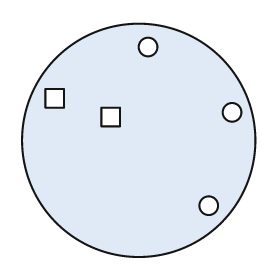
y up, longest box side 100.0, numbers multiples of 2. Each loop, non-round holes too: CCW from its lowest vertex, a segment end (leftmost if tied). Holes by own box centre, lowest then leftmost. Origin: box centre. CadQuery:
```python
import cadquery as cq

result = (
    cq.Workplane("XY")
    .moveTo(0.0, 0.0)
    .circle(50.0)
    .moveTo(30.0, -28.0)
    .circle(4.0)
    .moveTo(-16.0, 6.0)
    .lineTo(-8.0, 6.0)
    .lineTo(-8.0, 14.0)
    .lineTo(-16.0, 14.0)
    .close()
    .moveTo(40.0, 12.0)
    .circle(4.0)
    .moveTo(-40.0, 14.0)
    .lineTo(-32.0, 14.0)
    .lineTo(-32.0, 22.0)
    .lineTo(-40.0, 22.0)
    .close()
    .moveTo(4.0, 40.0)
    .circle(4.0)
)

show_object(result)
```